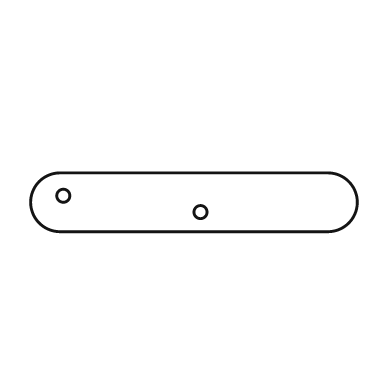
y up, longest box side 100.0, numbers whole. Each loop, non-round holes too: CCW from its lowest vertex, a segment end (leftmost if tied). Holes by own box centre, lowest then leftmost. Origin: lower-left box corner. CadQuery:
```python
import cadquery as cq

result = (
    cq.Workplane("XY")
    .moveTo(9.0, 0.0)
    .lineTo(91.0, 0.0)
    .threePointArc((100.0, 9.0), (91.0, 18.0))
    .lineTo(9.0, 18.0)
    .threePointArc((0.0, 9.0), (9.0, 0.0))
    .close()
    .moveTo(52.0, 6.0)
    .circle(2.0)
    .moveTo(10.0, 11.0)
    .circle(2.0)
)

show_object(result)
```